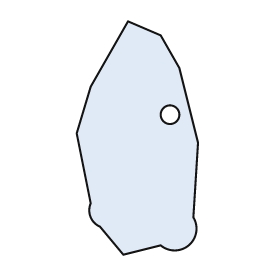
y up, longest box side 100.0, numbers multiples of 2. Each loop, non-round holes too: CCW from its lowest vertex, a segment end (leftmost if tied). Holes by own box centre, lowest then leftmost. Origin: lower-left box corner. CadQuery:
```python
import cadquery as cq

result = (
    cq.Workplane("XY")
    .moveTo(20.0, 0.0)
    .lineTo(36.0, 4.0)
    .threePointArc((48.0, 4.0), (50.0, 16.0))
    .lineTo(52.0, 48.0)
    .lineTo(44.0, 80.0)
    .lineTo(36.0, 94.0)
    .lineTo(22.0, 100.0)
    .lineTo(6.0, 72.0)
    .lineTo(0.0, 52.0)
    .lineTo(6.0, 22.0)
    .threePointArc((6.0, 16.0), (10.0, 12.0))
    .close()
    .moveTo(40.0, 60.0)
    .circle(4.0)
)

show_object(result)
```